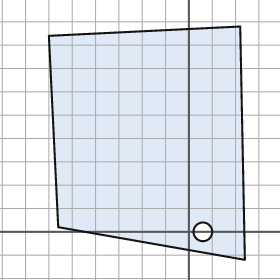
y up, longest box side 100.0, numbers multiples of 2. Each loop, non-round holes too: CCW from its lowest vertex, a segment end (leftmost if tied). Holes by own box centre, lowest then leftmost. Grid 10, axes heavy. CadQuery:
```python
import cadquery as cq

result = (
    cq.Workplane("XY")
    .moveTo(24.0, -12.0)
    .lineTo(22.0, 88.0)
    .lineTo(-60.0, 84.0)
    .lineTo(-56.0, 2.0)
    .close()
    .moveTo(6.0, 0.0)
    .circle(4.0)
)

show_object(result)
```